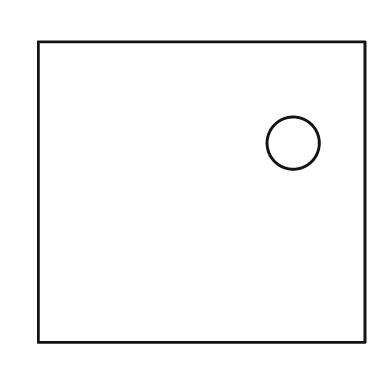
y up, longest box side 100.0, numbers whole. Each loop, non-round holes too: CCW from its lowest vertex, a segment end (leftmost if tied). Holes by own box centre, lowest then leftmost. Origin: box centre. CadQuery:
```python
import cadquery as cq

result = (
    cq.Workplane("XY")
    .moveTo(-50.0, -46.0)
    .lineTo(50.0, -46.0)
    .lineTo(50.0, 46.0)
    .lineTo(-50.0, 46.0)
    .close()
    .moveTo(28.0, 15.0)
    .circle(8.0)
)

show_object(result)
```